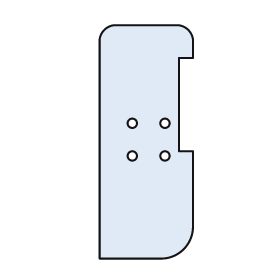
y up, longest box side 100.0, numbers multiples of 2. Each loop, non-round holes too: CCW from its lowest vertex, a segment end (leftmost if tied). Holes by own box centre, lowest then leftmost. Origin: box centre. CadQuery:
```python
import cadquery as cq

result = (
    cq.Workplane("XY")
    .moveTo(-20.0, -50.0)
    .lineTo(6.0, -50.0)
    .threePointArc((16.0, -46.0), (20.0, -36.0))
    .lineTo(20.0, -4.0)
    .lineTo(14.0, -4.0)
    .lineTo(14.0, 36.0)
    .lineTo(20.0, 36.0)
    .lineTo(20.0, 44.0)
    .threePointArc((18.0, 48.0), (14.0, 50.0))
    .lineTo(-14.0, 50.0)
    .threePointArc((-18.0, 48.0), (-20.0, 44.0))
    .close()
    .moveTo(-6.0, -6.0)
    .circle(2.0)
    .moveTo(8.0, -6.0)
    .circle(2.0)
    .moveTo(-6.0, 8.0)
    .circle(2.0)
    .moveTo(8.0, 8.0)
    .circle(2.0)
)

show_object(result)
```